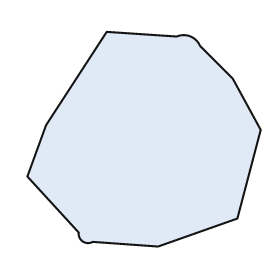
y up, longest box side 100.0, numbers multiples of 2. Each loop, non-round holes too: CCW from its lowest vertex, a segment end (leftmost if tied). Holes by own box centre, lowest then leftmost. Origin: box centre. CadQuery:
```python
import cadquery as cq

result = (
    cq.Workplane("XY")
    .moveTo(6.0, -46.0)
    .lineTo(40.0, -34.0)
    .lineTo(50.0, 4.0)
    .lineTo(38.0, 26.0)
    .lineTo(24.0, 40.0)
    .threePointArc((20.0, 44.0), (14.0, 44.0))
    .lineTo(-16.0, 46.0)
    .lineTo(-42.0, 6.0)
    .lineTo(-50.0, -16.0)
    .lineTo(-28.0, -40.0)
    .threePointArc((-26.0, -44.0), (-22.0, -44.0))
    .close()
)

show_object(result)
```